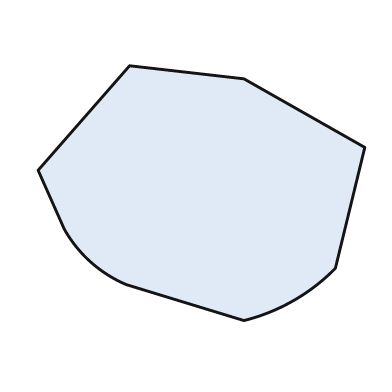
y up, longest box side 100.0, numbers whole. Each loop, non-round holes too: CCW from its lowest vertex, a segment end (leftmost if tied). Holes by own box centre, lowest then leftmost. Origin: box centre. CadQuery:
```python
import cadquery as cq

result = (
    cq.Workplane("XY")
    .moveTo(13.0, -39.0)
    .threePointArc((28.0, -33.0), (41.0, -23.0))
    .lineTo(50.0, 14.0)
    .lineTo(13.0, 35.0)
    .lineTo(-22.0, 39.0)
    .lineTo(-50.0, 7.0)
    .lineTo(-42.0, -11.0)
    .threePointArc((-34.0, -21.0), (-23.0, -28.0))
    .close()
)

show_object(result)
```